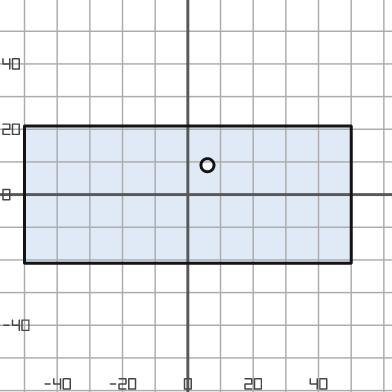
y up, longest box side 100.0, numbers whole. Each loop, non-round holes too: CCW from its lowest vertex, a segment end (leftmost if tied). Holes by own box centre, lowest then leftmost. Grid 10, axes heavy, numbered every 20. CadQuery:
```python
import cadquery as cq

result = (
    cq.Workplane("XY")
    .moveTo(-50.0, -21.0)
    .lineTo(50.0, -21.0)
    .lineTo(50.0, 21.0)
    .lineTo(-50.0, 21.0)
    .close()
    .moveTo(6.0, 9.0)
    .circle(2.0)
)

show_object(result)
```